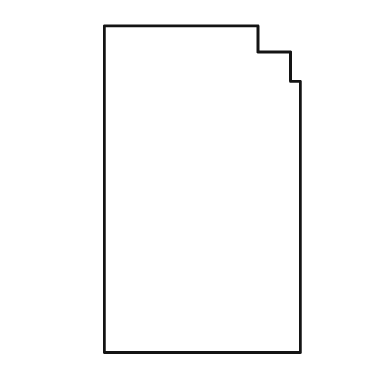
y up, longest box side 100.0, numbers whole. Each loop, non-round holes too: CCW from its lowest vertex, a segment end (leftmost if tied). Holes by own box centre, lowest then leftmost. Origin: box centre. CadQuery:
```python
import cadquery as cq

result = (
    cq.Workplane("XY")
    .moveTo(-30.0, -50.0)
    .lineTo(30.0, -50.0)
    .lineTo(30.0, 33.0)
    .lineTo(27.0, 33.0)
    .lineTo(27.0, 42.0)
    .lineTo(17.0, 42.0)
    .lineTo(17.0, 50.0)
    .lineTo(-30.0, 50.0)
    .close()
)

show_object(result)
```